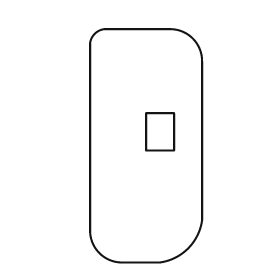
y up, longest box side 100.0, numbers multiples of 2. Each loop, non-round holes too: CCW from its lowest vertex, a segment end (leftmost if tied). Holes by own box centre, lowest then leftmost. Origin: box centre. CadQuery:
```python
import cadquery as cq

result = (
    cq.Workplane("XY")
    .moveTo(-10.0, -50.0)
    .lineTo(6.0, -50.0)
    .threePointArc((18.0, -44.0), (24.0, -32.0))
    .lineTo(24.0, 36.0)
    .threePointArc((20.0, 46.0), (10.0, 50.0))
    .lineTo(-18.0, 50.0)
    .threePointArc((-22.0, 48.0), (-24.0, 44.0))
    .lineTo(-24.0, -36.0)
    .threePointArc((-20.0, -46.0), (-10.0, -50.0))
    .close()
    .moveTo(0.0, -2.0)
    .lineTo(12.0, -2.0)
    .lineTo(12.0, 14.0)
    .lineTo(0.0, 14.0)
    .close()
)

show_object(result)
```